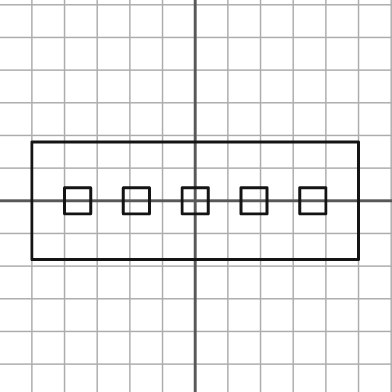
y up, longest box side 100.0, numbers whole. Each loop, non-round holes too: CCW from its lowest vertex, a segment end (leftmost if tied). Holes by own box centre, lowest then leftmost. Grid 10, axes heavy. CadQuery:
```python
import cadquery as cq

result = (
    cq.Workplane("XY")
    .moveTo(-50.0, -18.0)
    .lineTo(50.0, -18.0)
    .lineTo(50.0, 18.0)
    .lineTo(-50.0, 18.0)
    .close()
    .moveTo(-40.0, -4.0)
    .lineTo(-32.0, -4.0)
    .lineTo(-32.0, 4.0)
    .lineTo(-40.0, 4.0)
    .close()
    .moveTo(-22.0, -4.0)
    .lineTo(-14.0, -4.0)
    .lineTo(-14.0, 4.0)
    .lineTo(-22.0, 4.0)
    .close()
    .moveTo(-4.0, -4.0)
    .lineTo(4.0, -4.0)
    .lineTo(4.0, 4.0)
    .lineTo(-4.0, 4.0)
    .close()
    .moveTo(14.0, -4.0)
    .lineTo(22.0, -4.0)
    .lineTo(22.0, 4.0)
    .lineTo(14.0, 4.0)
    .close()
    .moveTo(32.0, -4.0)
    .lineTo(40.0, -4.0)
    .lineTo(40.0, 4.0)
    .lineTo(32.0, 4.0)
    .close()
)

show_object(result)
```